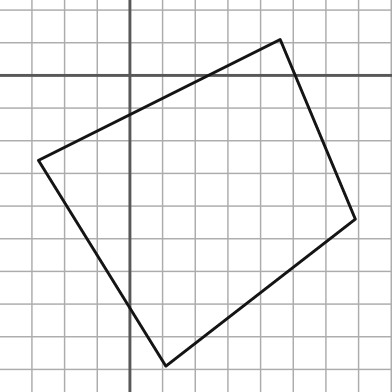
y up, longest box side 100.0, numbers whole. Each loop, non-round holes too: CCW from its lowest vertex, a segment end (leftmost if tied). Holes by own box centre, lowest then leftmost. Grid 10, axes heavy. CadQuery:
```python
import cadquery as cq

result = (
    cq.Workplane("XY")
    .moveTo(11.0, -89.0)
    .lineTo(69.0, -44.0)
    .lineTo(46.0, 11.0)
    .lineTo(-28.0, -26.0)
    .close()
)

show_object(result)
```